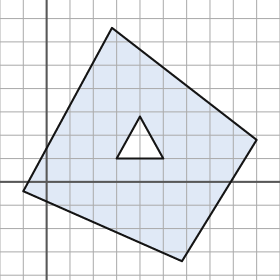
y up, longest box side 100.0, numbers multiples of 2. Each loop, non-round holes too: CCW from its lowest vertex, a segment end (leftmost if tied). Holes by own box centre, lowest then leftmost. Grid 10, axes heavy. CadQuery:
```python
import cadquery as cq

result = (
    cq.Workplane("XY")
    .moveTo(58.0, -34.0)
    .lineTo(90.0, 18.0)
    .lineTo(28.0, 66.0)
    .lineTo(-10.0, -4.0)
    .close()
    .moveTo(30.0, 10.0)
    .lineTo(50.0, 10.0)
    .lineTo(40.0, 28.0)
    .close()
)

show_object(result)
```